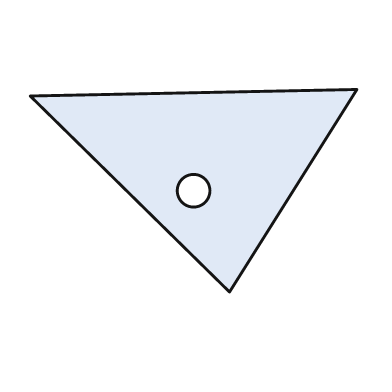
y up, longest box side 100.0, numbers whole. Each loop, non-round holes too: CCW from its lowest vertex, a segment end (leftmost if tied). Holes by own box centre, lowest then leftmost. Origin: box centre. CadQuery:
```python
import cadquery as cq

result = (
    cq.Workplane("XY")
    .moveTo(11.0, -31.0)
    .lineTo(50.0, 31.0)
    .lineTo(-50.0, 29.0)
    .close()
    .moveTo(0.0, 0.0)
    .circle(5.0)
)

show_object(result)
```